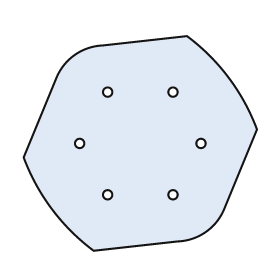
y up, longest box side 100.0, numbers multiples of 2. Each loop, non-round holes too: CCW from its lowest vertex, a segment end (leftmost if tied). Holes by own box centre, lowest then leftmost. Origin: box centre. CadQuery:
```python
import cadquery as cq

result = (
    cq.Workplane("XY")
    .moveTo(-20.0, -46.0)
    .lineTo(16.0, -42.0)
    .threePointArc((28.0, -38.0), (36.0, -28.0))
    .lineTo(50.0, 6.0)
    .threePointArc((38.0, 28.0), (20.0, 46.0))
    .lineTo(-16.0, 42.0)
    .threePointArc((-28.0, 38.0), (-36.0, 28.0))
    .lineTo(-50.0, -6.0)
    .threePointArc((-38.0, -28.0), (-20.0, -46.0))
    .close()
    .moveTo(-14.0, -22.0)
    .circle(2.0)
    .moveTo(14.0, -22.0)
    .circle(2.0)
    .moveTo(-26.0, 0.0)
    .circle(2.0)
    .moveTo(26.0, 0.0)
    .circle(2.0)
    .moveTo(-14.0, 22.0)
    .circle(2.0)
    .moveTo(14.0, 22.0)
    .circle(2.0)
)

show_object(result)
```